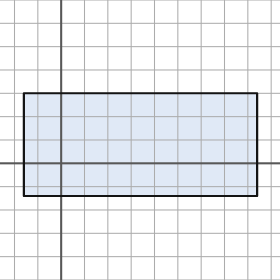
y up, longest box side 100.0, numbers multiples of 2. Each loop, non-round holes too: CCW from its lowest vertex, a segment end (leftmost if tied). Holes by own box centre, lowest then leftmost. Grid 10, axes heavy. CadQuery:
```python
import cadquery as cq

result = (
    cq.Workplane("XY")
    .moveTo(-16.0, -14.0)
    .lineTo(84.0, -14.0)
    .lineTo(84.0, 30.0)
    .lineTo(-16.0, 30.0)
    .close()
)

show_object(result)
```